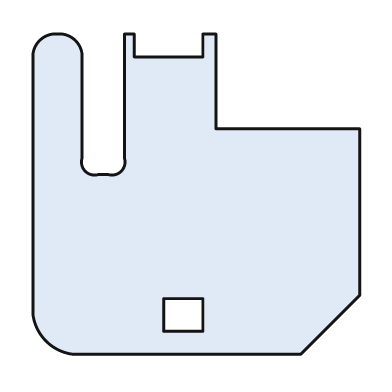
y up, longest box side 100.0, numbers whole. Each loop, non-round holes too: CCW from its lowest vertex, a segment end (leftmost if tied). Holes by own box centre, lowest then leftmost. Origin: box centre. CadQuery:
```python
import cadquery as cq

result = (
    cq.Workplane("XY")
    .moveTo(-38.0, -49.0)
    .lineTo(32.0, -49.0)
    .lineTo(50.0, -31.0)
    .lineTo(50.0, 20.0)
    .lineTo(6.0, 20.0)
    .lineTo(6.0, 49.0)
    .lineTo(2.0, 49.0)
    .lineTo(2.0, 42.0)
    .lineTo(-19.0, 42.0)
    .lineTo(-19.0, 49.0)
    .lineTo(-22.0, 49.0)
    .lineTo(-22.0, 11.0)
    .threePointArc((-23.0, 7.0), (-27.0, 6.0))
    .lineTo(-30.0, 6.0)
    .threePointArc((-34.0, 7.0), (-35.0, 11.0))
    .lineTo(-35.0, 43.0)
    .threePointArc((-37.0, 47.0), (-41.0, 49.0))
    .lineTo(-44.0, 49.0)
    .threePointArc((-48.0, 47.0), (-50.0, 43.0))
    .lineTo(-50.0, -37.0)
    .threePointArc((-46.0, -45.0), (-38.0, -49.0))
    .close()
    .moveTo(-10.0, -42.0)
    .lineTo(2.0, -42.0)
    .lineTo(2.0, -32.0)
    .lineTo(-10.0, -32.0)
    .close()
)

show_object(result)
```